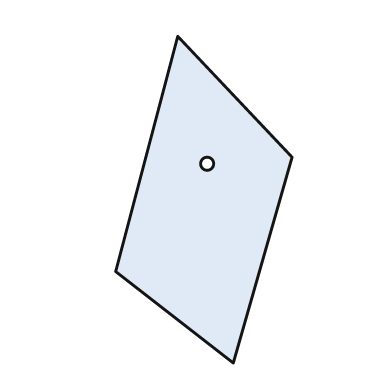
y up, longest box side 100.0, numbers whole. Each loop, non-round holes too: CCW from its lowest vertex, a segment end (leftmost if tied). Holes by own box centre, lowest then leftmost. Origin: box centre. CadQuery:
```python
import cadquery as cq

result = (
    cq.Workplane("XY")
    .moveTo(9.0, -50.0)
    .lineTo(27.0, 13.0)
    .lineTo(-8.0, 50.0)
    .lineTo(-27.0, -22.0)
    .close()
    .moveTo(1.0, 11.0)
    .circle(2.0)
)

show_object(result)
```